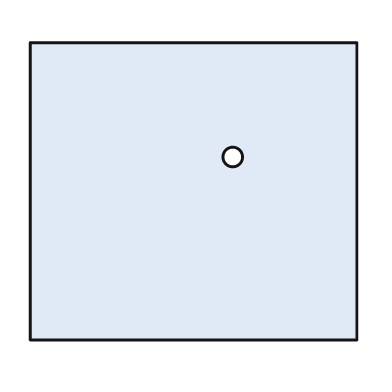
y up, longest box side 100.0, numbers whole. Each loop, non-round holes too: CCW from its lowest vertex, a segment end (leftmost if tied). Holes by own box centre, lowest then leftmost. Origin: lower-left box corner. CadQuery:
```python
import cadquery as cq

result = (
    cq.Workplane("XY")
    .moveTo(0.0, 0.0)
    .lineTo(100.0, 0.0)
    .lineTo(100.0, 91.0)
    .lineTo(0.0, 91.0)
    .close()
    .moveTo(62.0, 56.0)
    .circle(3.0)
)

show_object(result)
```